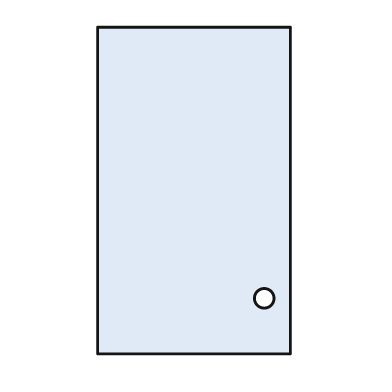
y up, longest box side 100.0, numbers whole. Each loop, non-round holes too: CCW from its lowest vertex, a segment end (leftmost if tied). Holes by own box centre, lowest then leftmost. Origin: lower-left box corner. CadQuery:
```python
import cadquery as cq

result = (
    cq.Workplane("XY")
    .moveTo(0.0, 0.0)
    .lineTo(59.0, 0.0)
    .lineTo(59.0, 100.0)
    .lineTo(0.0, 100.0)
    .close()
    .moveTo(51.0, 17.0)
    .circle(3.0)
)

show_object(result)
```